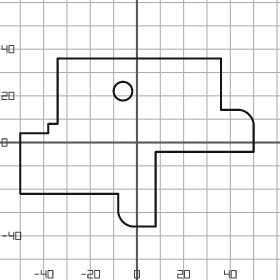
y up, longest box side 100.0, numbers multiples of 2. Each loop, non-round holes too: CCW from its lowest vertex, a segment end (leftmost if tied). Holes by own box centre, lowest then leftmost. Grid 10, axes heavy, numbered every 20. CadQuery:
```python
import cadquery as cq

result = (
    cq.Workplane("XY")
    .moveTo(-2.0, -36.0)
    .lineTo(8.0, -36.0)
    .lineTo(8.0, -4.0)
    .lineTo(50.0, -4.0)
    .lineTo(50.0, 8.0)
    .threePointArc((48.0, 12.0), (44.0, 14.0))
    .lineTo(36.0, 14.0)
    .lineTo(36.0, 36.0)
    .lineTo(-34.0, 36.0)
    .lineTo(-34.0, 8.0)
    .lineTo(-38.0, 8.0)
    .lineTo(-38.0, 4.0)
    .lineTo(-50.0, 4.0)
    .lineTo(-50.0, -22.0)
    .lineTo(-8.0, -22.0)
    .lineTo(-8.0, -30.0)
    .threePointArc((-6.0, -34.0), (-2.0, -36.0))
    .close()
    .moveTo(-6.0, 22.0)
    .circle(4.0)
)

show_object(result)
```